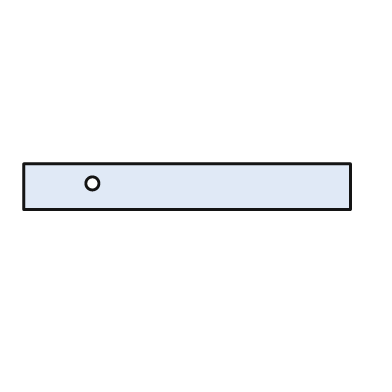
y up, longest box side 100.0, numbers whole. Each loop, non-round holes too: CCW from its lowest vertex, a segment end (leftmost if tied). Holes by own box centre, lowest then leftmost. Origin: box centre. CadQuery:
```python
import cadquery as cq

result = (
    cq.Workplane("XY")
    .moveTo(-50.0, -7.0)
    .lineTo(50.0, -7.0)
    .lineTo(50.0, 7.0)
    .lineTo(-50.0, 7.0)
    .close()
    .moveTo(-29.0, 1.0)
    .circle(2.0)
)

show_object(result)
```